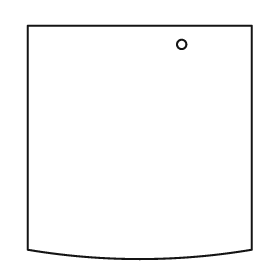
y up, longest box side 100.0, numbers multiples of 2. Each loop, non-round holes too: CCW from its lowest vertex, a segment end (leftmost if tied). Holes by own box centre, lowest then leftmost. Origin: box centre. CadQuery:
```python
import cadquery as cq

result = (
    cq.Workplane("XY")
    .moveTo(-48.0, -46.0)
    .threePointArc((0.0, -50.0), (48.0, -46.0))
    .lineTo(48.0, 50.0)
    .lineTo(-48.0, 50.0)
    .close()
    .moveTo(18.0, 42.0)
    .circle(2.0)
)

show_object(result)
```